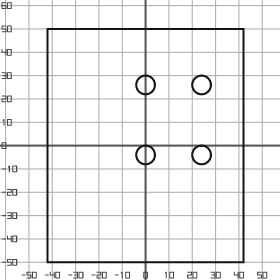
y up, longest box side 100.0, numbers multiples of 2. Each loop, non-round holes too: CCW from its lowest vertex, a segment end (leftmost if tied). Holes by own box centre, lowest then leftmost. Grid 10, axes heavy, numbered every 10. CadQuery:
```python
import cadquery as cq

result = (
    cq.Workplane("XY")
    .moveTo(-42.0, -50.0)
    .lineTo(42.0, -50.0)
    .lineTo(42.0, 50.0)
    .lineTo(-42.0, 50.0)
    .close()
    .moveTo(0.0, -4.0)
    .circle(4.0)
    .moveTo(24.0, -4.0)
    .circle(4.0)
    .moveTo(0.0, 26.0)
    .circle(4.0)
    .moveTo(24.0, 26.0)
    .circle(4.0)
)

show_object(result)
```